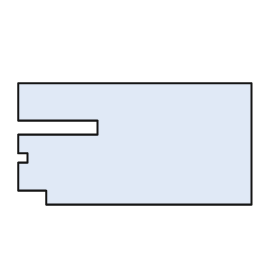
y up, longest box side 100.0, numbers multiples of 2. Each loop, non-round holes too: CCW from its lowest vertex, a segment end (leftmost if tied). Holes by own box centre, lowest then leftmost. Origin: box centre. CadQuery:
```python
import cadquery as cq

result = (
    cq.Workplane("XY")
    .moveTo(-38.0, -26.0)
    .lineTo(50.0, -26.0)
    .lineTo(50.0, 26.0)
    .lineTo(-50.0, 26.0)
    .lineTo(-50.0, 10.0)
    .lineTo(-16.0, 10.0)
    .lineTo(-16.0, 4.0)
    .lineTo(-50.0, 4.0)
    .lineTo(-50.0, -4.0)
    .lineTo(-46.0, -4.0)
    .lineTo(-46.0, -8.0)
    .lineTo(-50.0, -8.0)
    .lineTo(-50.0, -20.0)
    .lineTo(-38.0, -20.0)
    .close()
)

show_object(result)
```